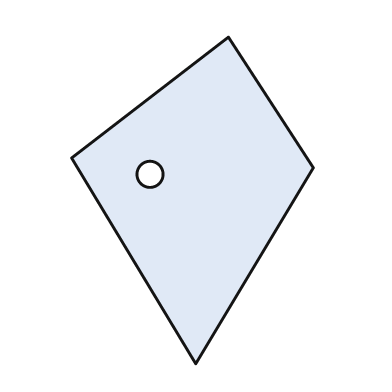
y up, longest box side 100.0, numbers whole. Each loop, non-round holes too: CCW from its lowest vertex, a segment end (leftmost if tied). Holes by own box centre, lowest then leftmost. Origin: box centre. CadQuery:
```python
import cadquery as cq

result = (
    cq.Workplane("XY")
    .moveTo(1.0, -50.0)
    .lineTo(37.0, 10.0)
    .lineTo(11.0, 50.0)
    .lineTo(-37.0, 13.0)
    .close()
    .moveTo(-13.0, 8.0)
    .circle(4.0)
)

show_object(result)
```